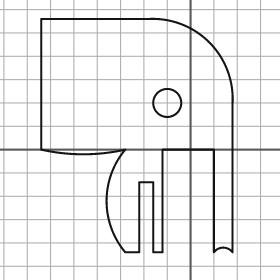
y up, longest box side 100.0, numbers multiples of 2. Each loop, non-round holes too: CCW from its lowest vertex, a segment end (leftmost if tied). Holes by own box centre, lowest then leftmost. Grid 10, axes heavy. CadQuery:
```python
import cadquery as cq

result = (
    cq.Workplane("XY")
    .moveTo(-28.0, -44.0)
    .lineTo(-22.0, -44.0)
    .lineTo(-22.0, -14.0)
    .lineTo(-16.0, -14.0)
    .lineTo(-16.0, -44.0)
    .lineTo(-12.0, -44.0)
    .lineTo(-12.0, 0.0)
    .lineTo(10.0, 0.0)
    .lineTo(10.0, -44.0)
    .threePointArc((14.0, -42.0), (18.0, -44.0))
    .lineTo(18.0, 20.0)
    .threePointArc((8.0, 46.0), (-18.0, 56.0))
    .lineTo(-64.0, 56.0)
    .lineTo(-64.0, 0.0)
    .threePointArc((-46.0, -2.0), (-28.0, 0.0))
    .threePointArc((-36.0, -22.0), (-28.0, -44.0))
    .close()
    .moveTo(-10.0, 20.0)
    .circle(6.0)
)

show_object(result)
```